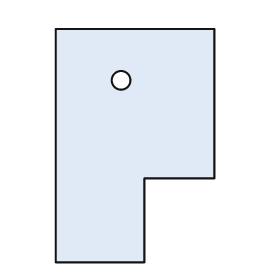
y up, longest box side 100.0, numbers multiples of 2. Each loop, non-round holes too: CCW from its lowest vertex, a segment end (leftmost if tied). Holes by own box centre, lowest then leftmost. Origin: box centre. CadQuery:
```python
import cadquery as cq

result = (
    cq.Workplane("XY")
    .moveTo(-34.0, -50.0)
    .lineTo(4.0, -50.0)
    .lineTo(4.0, -14.0)
    .lineTo(34.0, -14.0)
    .lineTo(34.0, 50.0)
    .lineTo(-34.0, 50.0)
    .close()
    .moveTo(-6.0, 28.0)
    .circle(4.0)
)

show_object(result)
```